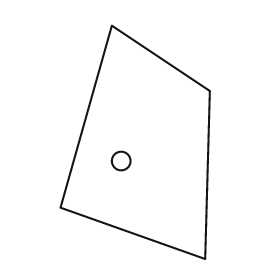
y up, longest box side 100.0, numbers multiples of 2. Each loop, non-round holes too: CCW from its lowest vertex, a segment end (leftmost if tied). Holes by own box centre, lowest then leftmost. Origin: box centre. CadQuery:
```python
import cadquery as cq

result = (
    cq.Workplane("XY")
    .moveTo(30.0, -50.0)
    .lineTo(32.0, 22.0)
    .lineTo(-10.0, 50.0)
    .lineTo(-32.0, -28.0)
    .close()
    .moveTo(-6.0, -8.0)
    .circle(4.0)
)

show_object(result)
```